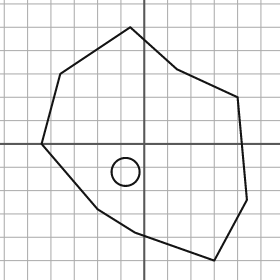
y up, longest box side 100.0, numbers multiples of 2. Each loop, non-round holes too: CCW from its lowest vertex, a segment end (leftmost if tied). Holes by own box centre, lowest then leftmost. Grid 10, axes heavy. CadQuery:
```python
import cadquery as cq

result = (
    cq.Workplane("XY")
    .moveTo(30.0, -50.0)
    .lineTo(44.0, -24.0)
    .lineTo(40.0, 20.0)
    .lineTo(14.0, 32.0)
    .lineTo(-6.0, 50.0)
    .lineTo(-36.0, 30.0)
    .lineTo(-44.0, 0.0)
    .lineTo(-20.0, -28.0)
    .lineTo(-4.0, -38.0)
    .close()
    .moveTo(-8.0, -12.0)
    .circle(6.0)
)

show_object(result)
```